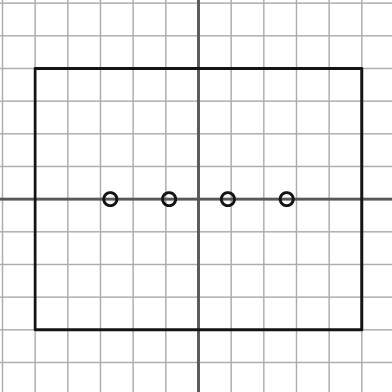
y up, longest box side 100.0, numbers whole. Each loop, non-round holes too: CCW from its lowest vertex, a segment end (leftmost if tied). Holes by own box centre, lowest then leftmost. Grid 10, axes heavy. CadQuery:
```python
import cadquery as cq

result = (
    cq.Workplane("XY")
    .moveTo(-50.0, -40.0)
    .lineTo(50.0, -40.0)
    .lineTo(50.0, 40.0)
    .lineTo(-50.0, 40.0)
    .close()
    .moveTo(-27.0, 0.0)
    .circle(2.0)
    .moveTo(-9.0, 0.0)
    .circle(2.0)
    .moveTo(9.0, 0.0)
    .circle(2.0)
    .moveTo(27.0, 0.0)
    .circle(2.0)
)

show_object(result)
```